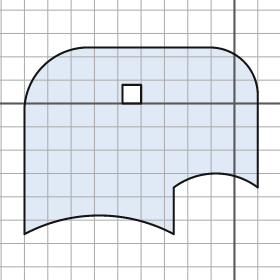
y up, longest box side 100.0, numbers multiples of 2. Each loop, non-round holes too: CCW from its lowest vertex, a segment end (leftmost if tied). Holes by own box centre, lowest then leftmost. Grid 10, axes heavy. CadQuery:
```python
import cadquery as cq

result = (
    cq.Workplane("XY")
    .moveTo(-90.0, -56.0)
    .threePointArc((-58.0, -48.0), (-26.0, -56.0))
    .lineTo(-26.0, -36.0)
    .threePointArc((-8.0, -30.0), (10.0, -36.0))
    .lineTo(10.0, 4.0)
    .threePointArc((4.0, 18.0), (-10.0, 24.0))
    .lineTo(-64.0, 24.0)
    .threePointArc((-82.0, 16.0), (-90.0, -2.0))
    .close()
    .moveTo(-48.0, 0.0)
    .lineTo(-40.0, 0.0)
    .lineTo(-40.0, 8.0)
    .lineTo(-48.0, 8.0)
    .close()
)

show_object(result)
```